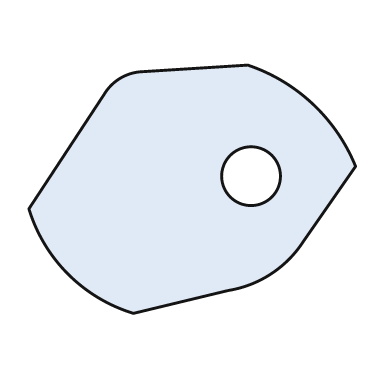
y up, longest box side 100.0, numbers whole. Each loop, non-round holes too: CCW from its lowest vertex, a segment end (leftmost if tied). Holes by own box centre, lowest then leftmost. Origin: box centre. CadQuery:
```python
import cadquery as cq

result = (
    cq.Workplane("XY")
    .moveTo(-18.0, -38.0)
    .lineTo(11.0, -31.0)
    .threePointArc((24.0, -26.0), (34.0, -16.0))
    .lineTo(50.0, 7.0)
    .threePointArc((37.0, 26.0), (17.0, 38.0))
    .lineTo(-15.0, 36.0)
    .threePointArc((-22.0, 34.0), (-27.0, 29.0))
    .lineTo(-50.0, -6.0)
    .threePointArc((-38.0, -26.0), (-18.0, -38.0))
    .close()
    .moveTo(18.0, 4.0)
    .circle(9.0)
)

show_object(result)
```